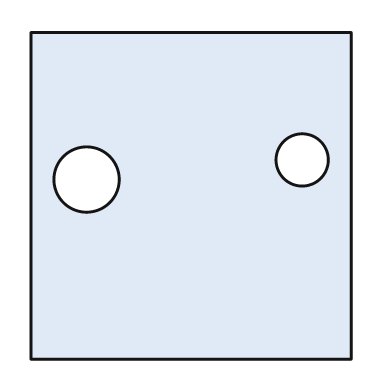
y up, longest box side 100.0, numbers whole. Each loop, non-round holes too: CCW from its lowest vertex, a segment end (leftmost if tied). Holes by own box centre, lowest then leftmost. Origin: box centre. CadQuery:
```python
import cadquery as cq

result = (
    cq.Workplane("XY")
    .moveTo(-49.0, -50.0)
    .lineTo(49.0, -50.0)
    .lineTo(49.0, 50.0)
    .lineTo(-49.0, 50.0)
    .close()
    .moveTo(-32.0, 5.0)
    .circle(10.0)
    .moveTo(34.0, 11.0)
    .circle(8.0)
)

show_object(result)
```